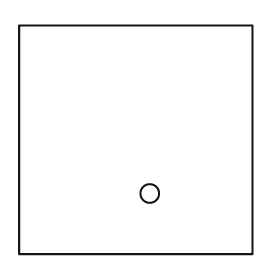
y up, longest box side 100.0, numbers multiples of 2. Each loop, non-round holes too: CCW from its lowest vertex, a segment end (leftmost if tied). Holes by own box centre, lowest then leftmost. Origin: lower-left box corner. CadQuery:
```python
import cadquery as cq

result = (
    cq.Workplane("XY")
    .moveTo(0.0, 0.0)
    .lineTo(100.0, 0.0)
    .lineTo(100.0, 98.0)
    .lineTo(0.0, 98.0)
    .close()
    .moveTo(56.0, 26.0)
    .circle(4.0)
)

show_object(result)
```